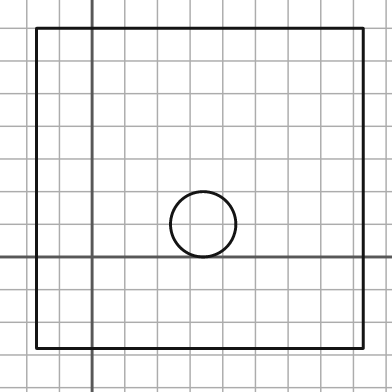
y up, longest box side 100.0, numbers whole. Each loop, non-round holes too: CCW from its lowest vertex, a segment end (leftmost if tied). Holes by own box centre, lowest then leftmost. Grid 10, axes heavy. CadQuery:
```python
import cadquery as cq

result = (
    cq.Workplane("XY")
    .moveTo(-17.0, -28.0)
    .lineTo(83.0, -28.0)
    .lineTo(83.0, 70.0)
    .lineTo(-17.0, 70.0)
    .close()
    .moveTo(34.0, 10.0)
    .circle(10.0)
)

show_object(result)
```